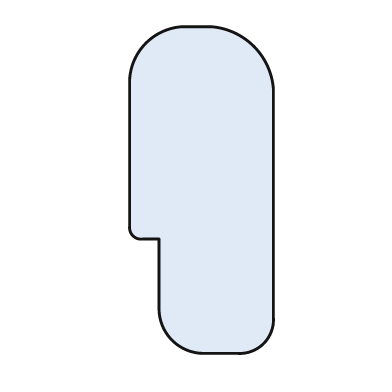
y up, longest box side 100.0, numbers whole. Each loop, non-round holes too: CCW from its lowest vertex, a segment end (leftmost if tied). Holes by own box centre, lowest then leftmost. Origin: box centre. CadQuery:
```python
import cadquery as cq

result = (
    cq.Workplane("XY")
    .moveTo(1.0, -50.0)
    .lineTo(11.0, -50.0)
    .threePointArc((19.0, -47.0), (22.0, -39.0))
    .lineTo(22.0, 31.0)
    .threePointArc((16.0, 44.0), (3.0, 50.0))
    .lineTo(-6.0, 50.0)
    .threePointArc((-17.0, 45.0), (-22.0, 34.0))
    .lineTo(-22.0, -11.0)
    .threePointArc((-21.0, -14.0), (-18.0, -15.0))
    .lineTo(-13.0, -15.0)
    .lineTo(-13.0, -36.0)
    .threePointArc((-9.0, -46.0), (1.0, -50.0))
    .close()
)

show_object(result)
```